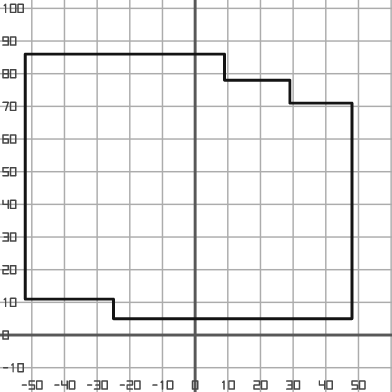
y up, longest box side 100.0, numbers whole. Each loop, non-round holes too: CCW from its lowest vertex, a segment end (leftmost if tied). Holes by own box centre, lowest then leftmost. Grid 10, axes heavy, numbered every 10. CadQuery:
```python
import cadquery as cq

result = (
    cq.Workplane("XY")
    .moveTo(-25.0, 5.0)
    .lineTo(48.0, 5.0)
    .lineTo(48.0, 71.0)
    .lineTo(29.0, 71.0)
    .lineTo(29.0, 78.0)
    .lineTo(9.0, 78.0)
    .lineTo(9.0, 86.0)
    .lineTo(-52.0, 86.0)
    .lineTo(-52.0, 11.0)
    .lineTo(-25.0, 11.0)
    .close()
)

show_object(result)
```